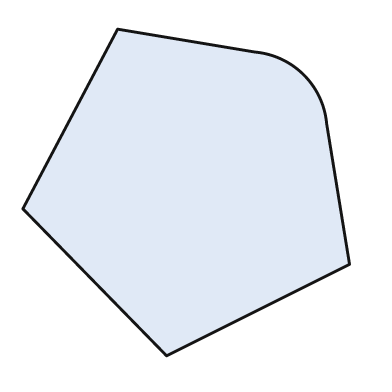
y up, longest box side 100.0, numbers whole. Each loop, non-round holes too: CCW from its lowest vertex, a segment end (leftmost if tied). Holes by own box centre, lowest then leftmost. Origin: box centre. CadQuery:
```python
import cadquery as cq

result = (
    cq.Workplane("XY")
    .moveTo(-6.0, -50.0)
    .lineTo(50.0, -22.0)
    .lineTo(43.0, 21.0)
    .threePointArc((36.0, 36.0), (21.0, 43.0))
    .lineTo(-21.0, 50.0)
    .lineTo(-50.0, -5.0)
    .close()
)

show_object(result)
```